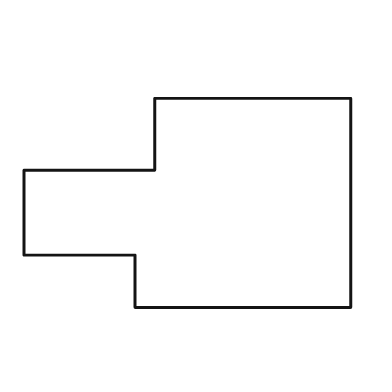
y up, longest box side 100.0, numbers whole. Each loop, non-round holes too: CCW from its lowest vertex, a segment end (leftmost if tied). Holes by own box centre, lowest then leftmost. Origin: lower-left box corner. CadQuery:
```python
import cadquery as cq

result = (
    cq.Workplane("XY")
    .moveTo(34.0, 0.0)
    .lineTo(100.0, 0.0)
    .lineTo(100.0, 64.0)
    .lineTo(40.0, 64.0)
    .lineTo(40.0, 42.0)
    .lineTo(0.0, 42.0)
    .lineTo(0.0, 16.0)
    .lineTo(34.0, 16.0)
    .close()
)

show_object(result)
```